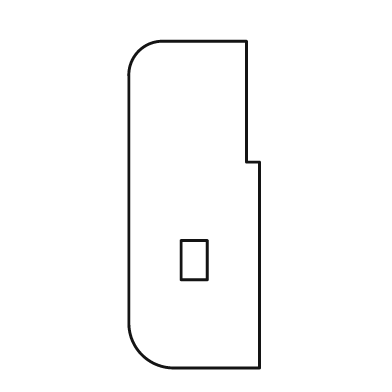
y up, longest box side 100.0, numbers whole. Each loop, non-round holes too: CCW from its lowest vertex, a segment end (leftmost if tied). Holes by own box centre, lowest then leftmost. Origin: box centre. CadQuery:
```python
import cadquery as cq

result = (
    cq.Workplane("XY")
    .moveTo(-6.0, -50.0)
    .lineTo(20.0, -50.0)
    .lineTo(20.0, 13.0)
    .lineTo(16.0, 13.0)
    .lineTo(16.0, 50.0)
    .lineTo(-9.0, 50.0)
    .threePointArc((-17.0, 47.0), (-20.0, 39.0))
    .lineTo(-20.0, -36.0)
    .threePointArc((-16.0, -46.0), (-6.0, -50.0))
    .close()
    .moveTo(-4.0, -23.0)
    .lineTo(4.0, -23.0)
    .lineTo(4.0, -11.0)
    .lineTo(-4.0, -11.0)
    .close()
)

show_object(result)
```